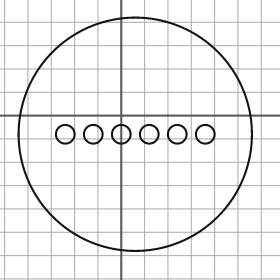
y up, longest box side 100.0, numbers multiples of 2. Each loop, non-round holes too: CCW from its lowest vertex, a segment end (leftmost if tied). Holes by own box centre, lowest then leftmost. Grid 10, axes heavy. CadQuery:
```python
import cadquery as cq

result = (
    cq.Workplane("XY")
    .moveTo(6.0, -8.0)
    .circle(50.0)
    .moveTo(-24.0, -8.0)
    .circle(4.0)
    .moveTo(-12.0, -8.0)
    .circle(4.0)
    .moveTo(0.0, -8.0)
    .circle(4.0)
    .moveTo(12.0, -8.0)
    .circle(4.0)
    .moveTo(24.0, -8.0)
    .circle(4.0)
    .moveTo(36.0, -8.0)
    .circle(4.0)
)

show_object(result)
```